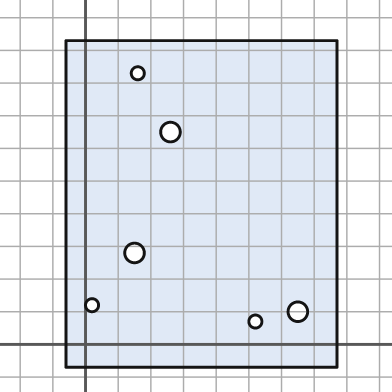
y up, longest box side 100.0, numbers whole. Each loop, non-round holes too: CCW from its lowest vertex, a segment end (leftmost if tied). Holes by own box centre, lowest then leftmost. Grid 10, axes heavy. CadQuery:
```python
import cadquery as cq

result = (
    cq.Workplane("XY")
    .moveTo(-6.0, -7.0)
    .lineTo(77.0, -7.0)
    .lineTo(77.0, 93.0)
    .lineTo(-6.0, 93.0)
    .close()
    .moveTo(52.0, 7.0)
    .circle(2.0)
    .moveTo(65.0, 10.0)
    .circle(3.0)
    .moveTo(2.0, 12.0)
    .circle(2.0)
    .moveTo(15.0, 28.0)
    .circle(3.0)
    .moveTo(26.0, 65.0)
    .circle(3.0)
    .moveTo(16.0, 83.0)
    .circle(2.0)
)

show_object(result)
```